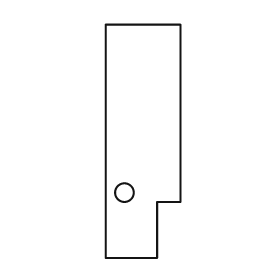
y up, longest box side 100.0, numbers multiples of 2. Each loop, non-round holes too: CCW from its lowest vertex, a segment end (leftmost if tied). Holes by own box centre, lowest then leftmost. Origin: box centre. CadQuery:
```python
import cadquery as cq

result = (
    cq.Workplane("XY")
    .moveTo(-16.0, -50.0)
    .lineTo(6.0, -50.0)
    .lineTo(6.0, -26.0)
    .lineTo(16.0, -26.0)
    .lineTo(16.0, 50.0)
    .lineTo(-16.0, 50.0)
    .close()
    .moveTo(-8.0, -22.0)
    .circle(4.0)
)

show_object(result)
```